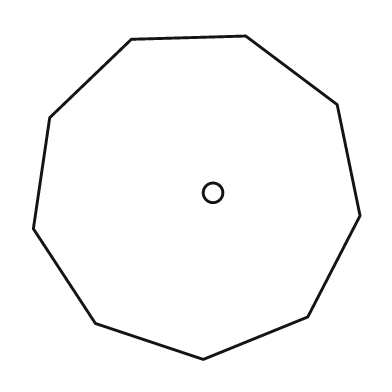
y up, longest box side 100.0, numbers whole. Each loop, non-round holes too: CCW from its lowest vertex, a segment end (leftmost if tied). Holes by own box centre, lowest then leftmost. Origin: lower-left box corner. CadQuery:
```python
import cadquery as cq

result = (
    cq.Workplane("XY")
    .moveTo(52.0, 0.0)
    .lineTo(84.0, 13.0)
    .lineTo(100.0, 44.0)
    .lineTo(93.0, 78.0)
    .lineTo(65.0, 99.0)
    .lineTo(30.0, 98.0)
    .lineTo(5.0, 74.0)
    .lineTo(0.0, 40.0)
    .lineTo(19.0, 11.0)
    .close()
    .moveTo(55.0, 51.0)
    .circle(3.0)
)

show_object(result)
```